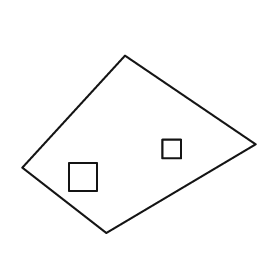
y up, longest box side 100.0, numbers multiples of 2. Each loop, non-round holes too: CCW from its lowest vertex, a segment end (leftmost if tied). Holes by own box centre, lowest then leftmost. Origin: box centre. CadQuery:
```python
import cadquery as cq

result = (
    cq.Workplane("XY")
    .moveTo(-14.0, -38.0)
    .lineTo(50.0, 0.0)
    .lineTo(-6.0, 38.0)
    .lineTo(-50.0, -10.0)
    .close()
    .moveTo(-30.0, -20.0)
    .lineTo(-18.0, -20.0)
    .lineTo(-18.0, -8.0)
    .lineTo(-30.0, -8.0)
    .close()
    .moveTo(10.0, -6.0)
    .lineTo(18.0, -6.0)
    .lineTo(18.0, 2.0)
    .lineTo(10.0, 2.0)
    .close()
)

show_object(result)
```